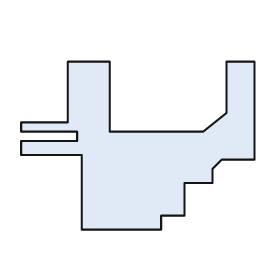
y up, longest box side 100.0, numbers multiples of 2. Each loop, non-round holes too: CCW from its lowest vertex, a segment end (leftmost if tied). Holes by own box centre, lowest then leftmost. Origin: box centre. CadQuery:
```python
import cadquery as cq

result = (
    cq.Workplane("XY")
    .moveTo(-24.0, -36.0)
    .lineTo(10.0, -36.0)
    .lineTo(10.0, -30.0)
    .lineTo(20.0, -30.0)
    .lineTo(20.0, -16.0)
    .lineTo(32.0, -16.0)
    .lineTo(32.0, -10.0)
    .lineTo(36.0, -6.0)
    .lineTo(50.0, -6.0)
    .lineTo(50.0, 36.0)
    .lineTo(38.0, 36.0)
    .lineTo(38.0, 14.0)
    .lineTo(28.0, 6.0)
    .lineTo(-12.0, 6.0)
    .lineTo(-12.0, 36.0)
    .lineTo(-30.0, 36.0)
    .lineTo(-30.0, 10.0)
    .lineTo(-50.0, 10.0)
    .lineTo(-50.0, 6.0)
    .lineTo(-26.0, 6.0)
    .lineTo(-26.0, 2.0)
    .lineTo(-50.0, 2.0)
    .lineTo(-50.0, -4.0)
    .lineTo(-24.0, -4.0)
    .close()
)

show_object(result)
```